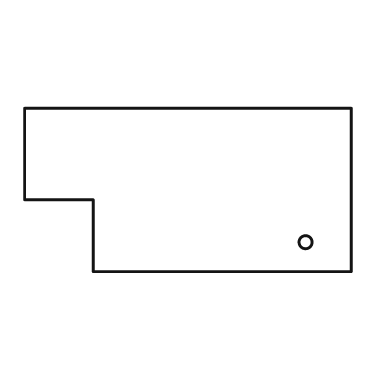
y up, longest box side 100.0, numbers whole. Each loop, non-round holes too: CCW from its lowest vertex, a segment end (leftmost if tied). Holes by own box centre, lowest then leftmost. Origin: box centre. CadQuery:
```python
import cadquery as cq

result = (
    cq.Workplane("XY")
    .moveTo(-29.0, -25.0)
    .lineTo(50.0, -25.0)
    .lineTo(50.0, 25.0)
    .lineTo(-50.0, 25.0)
    .lineTo(-50.0, -3.0)
    .lineTo(-29.0, -3.0)
    .close()
    .moveTo(36.0, -16.0)
    .circle(2.0)
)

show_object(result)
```